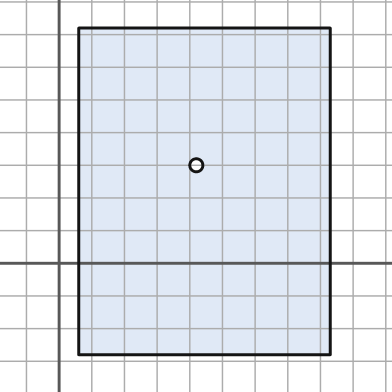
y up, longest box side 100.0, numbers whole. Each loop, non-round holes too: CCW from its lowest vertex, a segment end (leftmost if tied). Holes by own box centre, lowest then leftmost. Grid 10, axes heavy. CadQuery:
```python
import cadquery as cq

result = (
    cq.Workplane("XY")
    .moveTo(6.0, -28.0)
    .lineTo(83.0, -28.0)
    .lineTo(83.0, 72.0)
    .lineTo(6.0, 72.0)
    .close()
    .moveTo(42.0, 30.0)
    .circle(2.0)
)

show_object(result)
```